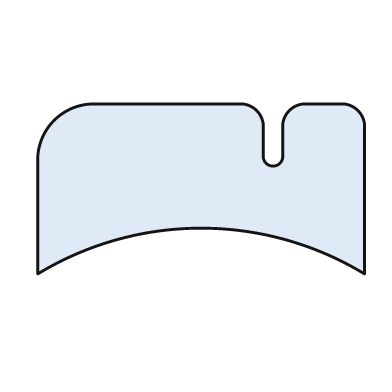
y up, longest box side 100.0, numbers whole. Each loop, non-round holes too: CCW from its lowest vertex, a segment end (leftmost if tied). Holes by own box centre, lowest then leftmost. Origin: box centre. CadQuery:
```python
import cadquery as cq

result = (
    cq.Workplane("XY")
    .moveTo(-50.0, -26.0)
    .threePointArc((0.0, -12.0), (50.0, -26.0))
    .lineTo(50.0, 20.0)
    .threePointArc((48.0, 24.0), (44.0, 26.0))
    .lineTo(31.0, 26.0)
    .threePointArc((27.0, 24.0), (25.0, 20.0))
    .lineTo(25.0, 10.0)
    .threePointArc((22.0, 7.0), (19.0, 10.0))
    .lineTo(19.0, 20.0)
    .threePointArc((17.0, 24.0), (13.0, 26.0))
    .lineTo(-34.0, 26.0)
    .threePointArc((-45.0, 21.0), (-50.0, 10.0))
    .close()
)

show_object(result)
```